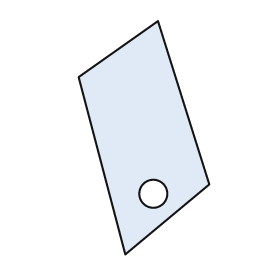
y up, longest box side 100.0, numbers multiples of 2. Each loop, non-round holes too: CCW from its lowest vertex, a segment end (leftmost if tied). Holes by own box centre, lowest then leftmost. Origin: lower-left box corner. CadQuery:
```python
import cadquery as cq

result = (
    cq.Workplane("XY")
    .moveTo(20.0, 0.0)
    .lineTo(56.0, 30.0)
    .lineTo(34.0, 100.0)
    .lineTo(0.0, 76.0)
    .close()
    .moveTo(32.0, 26.0)
    .circle(6.0)
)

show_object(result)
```